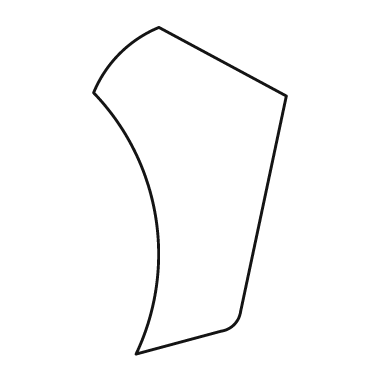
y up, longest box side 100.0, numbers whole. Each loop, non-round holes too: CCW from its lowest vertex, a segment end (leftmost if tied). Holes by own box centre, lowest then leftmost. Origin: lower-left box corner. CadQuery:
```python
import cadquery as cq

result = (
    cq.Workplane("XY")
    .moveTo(13.0, 0.0)
    .lineTo(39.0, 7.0)
    .threePointArc((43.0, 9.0), (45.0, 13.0))
    .lineTo(59.0, 79.0)
    .lineTo(20.0, 100.0)
    .threePointArc((8.0, 92.0), (0.0, 80.0))
    .threePointArc((19.0, 42.0), (13.0, 0.0))
    .close()
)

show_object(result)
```